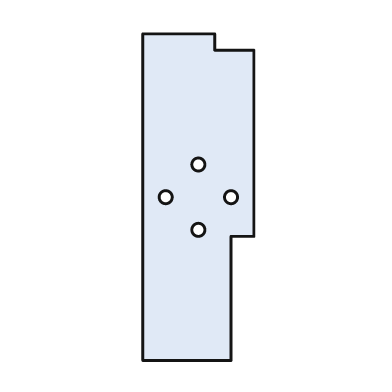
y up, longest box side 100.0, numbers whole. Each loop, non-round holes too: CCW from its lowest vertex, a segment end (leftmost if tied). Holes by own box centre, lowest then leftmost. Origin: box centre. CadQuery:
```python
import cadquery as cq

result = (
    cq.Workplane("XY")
    .moveTo(-17.0, -50.0)
    .lineTo(10.0, -50.0)
    .lineTo(10.0, -12.0)
    .lineTo(17.0, -12.0)
    .lineTo(17.0, 45.0)
    .lineTo(5.0, 45.0)
    .lineTo(5.0, 50.0)
    .lineTo(-17.0, 50.0)
    .close()
    .moveTo(0.0, -10.0)
    .circle(2.0)
    .moveTo(-10.0, 0.0)
    .circle(2.0)
    .moveTo(10.0, 0.0)
    .circle(2.0)
    .moveTo(0.0, 10.0)
    .circle(2.0)
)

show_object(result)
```